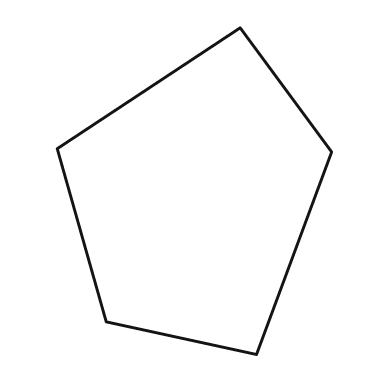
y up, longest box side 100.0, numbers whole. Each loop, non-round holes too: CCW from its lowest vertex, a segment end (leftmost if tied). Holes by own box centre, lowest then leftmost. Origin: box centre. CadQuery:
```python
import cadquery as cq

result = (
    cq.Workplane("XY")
    .moveTo(19.0, -50.0)
    .lineTo(42.0, 12.0)
    .lineTo(14.0, 50.0)
    .lineTo(-42.0, 13.0)
    .lineTo(-27.0, -40.0)
    .close()
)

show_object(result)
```